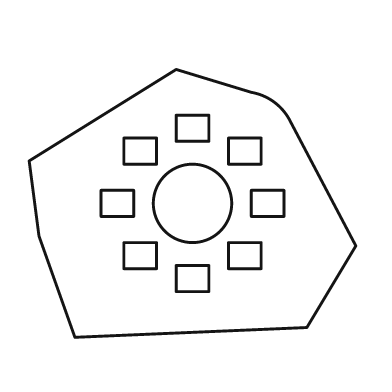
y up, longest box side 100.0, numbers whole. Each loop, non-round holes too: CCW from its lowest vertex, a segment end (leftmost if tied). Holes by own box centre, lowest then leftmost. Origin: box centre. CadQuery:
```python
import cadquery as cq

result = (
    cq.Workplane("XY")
    .moveTo(-36.0, -41.0)
    .lineTo(35.0, -38.0)
    .lineTo(50.0, -13.0)
    .lineTo(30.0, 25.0)
    .threePointArc((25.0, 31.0), (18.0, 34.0))
    .lineTo(-5.0, 41.0)
    .lineTo(-50.0, 13.0)
    .lineTo(-47.0, -10.0)
    .close()
    .moveTo(-5.0, -27.0)
    .lineTo(5.0, -27.0)
    .lineTo(5.0, -19.0)
    .lineTo(-5.0, -19.0)
    .close()
    .moveTo(-21.0, -20.0)
    .lineTo(-11.0, -20.0)
    .lineTo(-11.0, -12.0)
    .lineTo(-21.0, -12.0)
    .close()
    .moveTo(11.0, -20.0)
    .lineTo(21.0, -20.0)
    .lineTo(21.0, -12.0)
    .lineTo(11.0, -12.0)
    .close()
    .moveTo(-28.0, -4.0)
    .lineTo(-18.0, -4.0)
    .lineTo(-18.0, 4.0)
    .lineTo(-28.0, 4.0)
    .close()
    .moveTo(0.0, 0.0)
    .circle(12.0)
    .moveTo(18.0, -4.0)
    .lineTo(28.0, -4.0)
    .lineTo(28.0, 4.0)
    .lineTo(18.0, 4.0)
    .close()
    .moveTo(-21.0, 12.0)
    .lineTo(-11.0, 12.0)
    .lineTo(-11.0, 20.0)
    .lineTo(-21.0, 20.0)
    .close()
    .moveTo(11.0, 12.0)
    .lineTo(21.0, 12.0)
    .lineTo(21.0, 20.0)
    .lineTo(11.0, 20.0)
    .close()
    .moveTo(-5.0, 19.0)
    .lineTo(5.0, 19.0)
    .lineTo(5.0, 27.0)
    .lineTo(-5.0, 27.0)
    .close()
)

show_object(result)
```